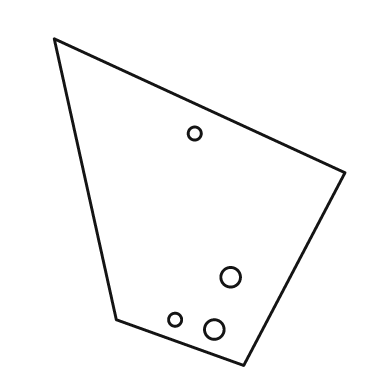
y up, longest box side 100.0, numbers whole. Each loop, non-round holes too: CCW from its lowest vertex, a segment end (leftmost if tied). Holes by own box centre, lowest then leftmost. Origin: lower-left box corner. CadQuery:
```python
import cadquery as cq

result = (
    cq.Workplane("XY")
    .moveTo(58.0, 0.0)
    .lineTo(89.0, 59.0)
    .lineTo(0.0, 100.0)
    .lineTo(19.0, 14.0)
    .close()
    .moveTo(49.0, 11.0)
    .circle(3.0)
    .moveTo(37.0, 14.0)
    .circle(2.0)
    .moveTo(54.0, 27.0)
    .circle(3.0)
    .moveTo(43.0, 71.0)
    .circle(2.0)
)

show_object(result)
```